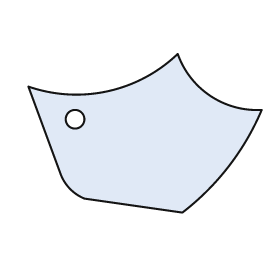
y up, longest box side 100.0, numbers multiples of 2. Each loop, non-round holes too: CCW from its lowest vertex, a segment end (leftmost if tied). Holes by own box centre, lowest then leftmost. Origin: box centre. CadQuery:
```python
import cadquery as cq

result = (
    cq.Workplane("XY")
    .moveTo(16.0, -34.0)
    .threePointArc((36.0, -14.0), (50.0, 10.0))
    .threePointArc((28.0, 16.0), (14.0, 34.0))
    .threePointArc((-16.0, 18.0), (-50.0, 20.0))
    .lineTo(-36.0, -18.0)
    .threePointArc((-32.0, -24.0), (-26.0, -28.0))
    .close()
    .moveTo(-30.0, 6.0)
    .circle(4.0)
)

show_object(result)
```